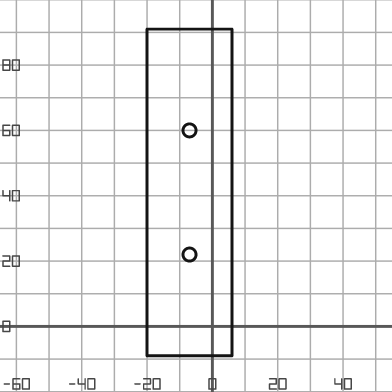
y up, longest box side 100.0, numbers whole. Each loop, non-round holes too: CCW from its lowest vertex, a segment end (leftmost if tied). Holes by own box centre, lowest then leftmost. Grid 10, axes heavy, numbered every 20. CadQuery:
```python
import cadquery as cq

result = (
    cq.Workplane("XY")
    .moveTo(-20.0, -9.0)
    .lineTo(6.0, -9.0)
    .lineTo(6.0, 91.0)
    .lineTo(-20.0, 91.0)
    .close()
    .moveTo(-7.0, 22.0)
    .circle(2.0)
    .moveTo(-7.0, 60.0)
    .circle(2.0)
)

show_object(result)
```